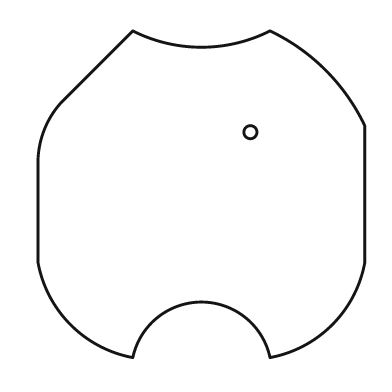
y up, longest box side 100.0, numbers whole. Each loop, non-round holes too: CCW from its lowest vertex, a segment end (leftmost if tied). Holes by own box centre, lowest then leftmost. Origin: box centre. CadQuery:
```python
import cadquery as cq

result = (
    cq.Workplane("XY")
    .moveTo(-21.0, -50.0)
    .threePointArc((0.0, -33.0), (21.0, -50.0))
    .threePointArc((40.0, -40.0), (50.0, -21.0))
    .lineTo(50.0, 21.0)
    .threePointArc((38.0, 38.0), (21.0, 50.0))
    .threePointArc((0.0, 45.0), (-21.0, 50.0))
    .lineTo(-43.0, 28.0)
    .threePointArc((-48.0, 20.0), (-50.0, 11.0))
    .lineTo(-50.0, -21.0)
    .threePointArc((-40.0, -40.0), (-21.0, -50.0))
    .close()
    .moveTo(15.0, 19.0)
    .circle(2.0)
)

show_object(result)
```